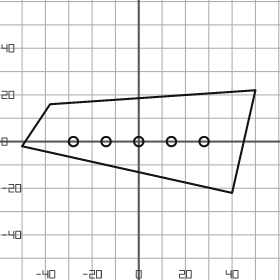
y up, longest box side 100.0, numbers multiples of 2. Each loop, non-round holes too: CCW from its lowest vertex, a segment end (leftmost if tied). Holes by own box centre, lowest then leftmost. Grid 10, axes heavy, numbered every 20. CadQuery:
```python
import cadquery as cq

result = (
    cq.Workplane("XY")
    .moveTo(40.0, -22.0)
    .lineTo(50.0, 22.0)
    .lineTo(-38.0, 16.0)
    .lineTo(-50.0, -2.0)
    .close()
    .moveTo(-28.0, 0.0)
    .circle(2.0)
    .moveTo(-14.0, 0.0)
    .circle(2.0)
    .moveTo(0.0, 0.0)
    .circle(2.0)
    .moveTo(14.0, 0.0)
    .circle(2.0)
    .moveTo(28.0, 0.0)
    .circle(2.0)
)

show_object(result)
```